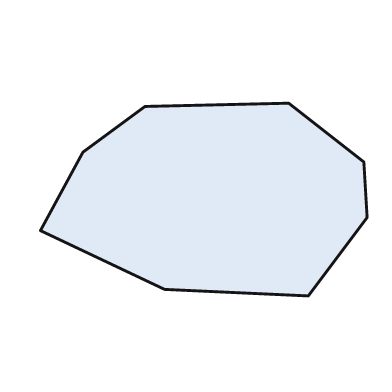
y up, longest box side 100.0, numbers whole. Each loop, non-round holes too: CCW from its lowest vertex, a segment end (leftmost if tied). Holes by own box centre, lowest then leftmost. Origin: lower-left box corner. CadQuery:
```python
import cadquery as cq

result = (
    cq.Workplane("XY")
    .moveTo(82.0, 0.0)
    .lineTo(100.0, 24.0)
    .lineTo(99.0, 41.0)
    .lineTo(76.0, 59.0)
    .lineTo(32.0, 58.0)
    .lineTo(13.0, 44.0)
    .lineTo(0.0, 20.0)
    .lineTo(38.0, 2.0)
    .close()
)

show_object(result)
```